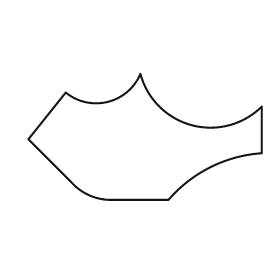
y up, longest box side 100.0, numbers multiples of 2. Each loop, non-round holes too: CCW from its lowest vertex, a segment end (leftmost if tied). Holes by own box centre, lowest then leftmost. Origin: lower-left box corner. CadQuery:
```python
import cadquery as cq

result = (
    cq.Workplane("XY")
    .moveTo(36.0, 0.0)
    .lineTo(60.0, 0.0)
    .threePointArc((78.0, 14.0), (100.0, 20.0))
    .lineTo(100.0, 40.0)
    .threePointArc((70.0, 32.0), (48.0, 54.0))
    .threePointArc((34.0, 42.0), (16.0, 46.0))
    .lineTo(0.0, 26.0)
    .lineTo(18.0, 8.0)
    .threePointArc((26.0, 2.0), (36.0, 0.0))
    .close()
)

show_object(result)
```